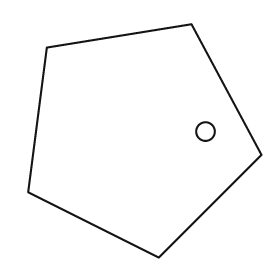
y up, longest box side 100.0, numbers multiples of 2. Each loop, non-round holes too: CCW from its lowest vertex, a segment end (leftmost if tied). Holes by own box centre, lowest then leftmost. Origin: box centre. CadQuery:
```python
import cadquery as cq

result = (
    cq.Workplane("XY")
    .moveTo(6.0, -50.0)
    .lineTo(50.0, -6.0)
    .lineTo(20.0, 50.0)
    .lineTo(-42.0, 40.0)
    .lineTo(-50.0, -22.0)
    .close()
    .moveTo(26.0, 4.0)
    .circle(4.0)
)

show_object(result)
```